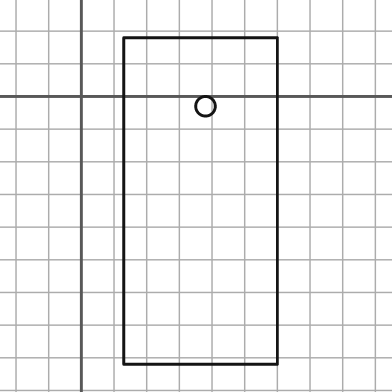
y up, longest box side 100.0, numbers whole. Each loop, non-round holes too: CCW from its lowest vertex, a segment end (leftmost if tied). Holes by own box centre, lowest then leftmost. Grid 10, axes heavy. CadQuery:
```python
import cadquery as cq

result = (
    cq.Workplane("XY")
    .moveTo(13.0, -82.0)
    .lineTo(60.0, -82.0)
    .lineTo(60.0, 18.0)
    .lineTo(13.0, 18.0)
    .close()
    .moveTo(38.0, -3.0)
    .circle(3.0)
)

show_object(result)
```